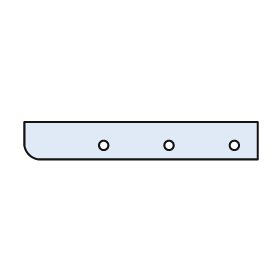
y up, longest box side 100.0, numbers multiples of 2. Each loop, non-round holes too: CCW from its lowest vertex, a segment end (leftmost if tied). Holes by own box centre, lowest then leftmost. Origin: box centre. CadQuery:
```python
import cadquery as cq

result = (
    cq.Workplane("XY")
    .moveTo(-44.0, -8.0)
    .lineTo(50.0, -8.0)
    .lineTo(50.0, 8.0)
    .lineTo(-50.0, 8.0)
    .lineTo(-50.0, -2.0)
    .threePointArc((-48.0, -6.0), (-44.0, -8.0))
    .close()
    .moveTo(-16.0, -2.0)
    .circle(2.0)
    .moveTo(12.0, -2.0)
    .circle(2.0)
    .moveTo(40.0, -2.0)
    .circle(2.0)
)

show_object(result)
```